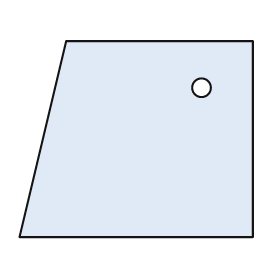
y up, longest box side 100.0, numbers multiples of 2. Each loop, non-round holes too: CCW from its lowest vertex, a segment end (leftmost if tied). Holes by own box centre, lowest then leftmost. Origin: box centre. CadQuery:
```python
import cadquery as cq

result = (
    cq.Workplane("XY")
    .moveTo(-50.0, -42.0)
    .lineTo(50.0, -42.0)
    .lineTo(50.0, 42.0)
    .lineTo(-30.0, 42.0)
    .close()
    .moveTo(28.0, 22.0)
    .circle(4.0)
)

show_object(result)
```